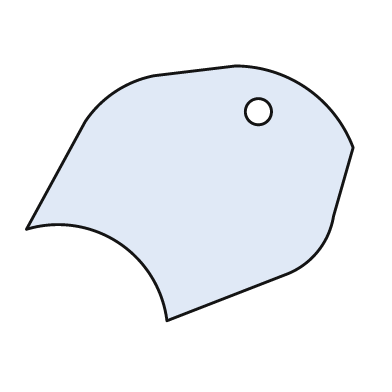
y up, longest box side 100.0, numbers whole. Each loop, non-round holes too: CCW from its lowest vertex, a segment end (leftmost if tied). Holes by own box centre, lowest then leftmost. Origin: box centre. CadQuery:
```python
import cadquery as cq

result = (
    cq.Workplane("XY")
    .moveTo(-7.0, -39.0)
    .lineTo(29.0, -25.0)
    .threePointArc((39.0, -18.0), (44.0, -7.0))
    .lineTo(50.0, 14.0)
    .threePointArc((36.0, 32.0), (14.0, 39.0))
    .lineTo(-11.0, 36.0)
    .threePointArc((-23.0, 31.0), (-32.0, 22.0))
    .lineTo(-50.0, -11.0)
    .threePointArc((-22.0, -15.0), (-7.0, -39.0))
    .close()
    .moveTo(21.0, 25.0)
    .circle(4.0)
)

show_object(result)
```